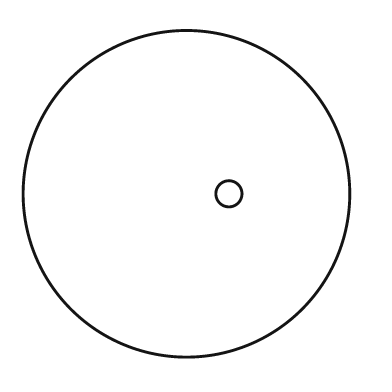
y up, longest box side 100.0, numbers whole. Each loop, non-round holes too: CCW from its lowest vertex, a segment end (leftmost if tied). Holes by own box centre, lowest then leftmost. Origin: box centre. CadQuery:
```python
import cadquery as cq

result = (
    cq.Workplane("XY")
    .moveTo(0.0, 0.0)
    .circle(50.0)
    .moveTo(13.0, 0.0)
    .circle(4.0)
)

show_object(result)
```